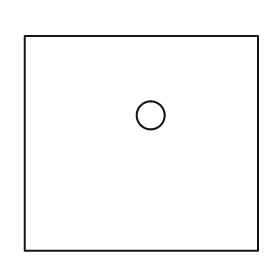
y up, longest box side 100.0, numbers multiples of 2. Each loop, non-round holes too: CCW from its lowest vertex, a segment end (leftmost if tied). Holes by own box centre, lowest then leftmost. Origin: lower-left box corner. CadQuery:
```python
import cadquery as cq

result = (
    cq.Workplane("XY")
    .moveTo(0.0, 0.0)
    .lineTo(100.0, 0.0)
    .lineTo(100.0, 92.0)
    .lineTo(0.0, 92.0)
    .close()
    .moveTo(54.0, 58.0)
    .circle(6.0)
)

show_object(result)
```